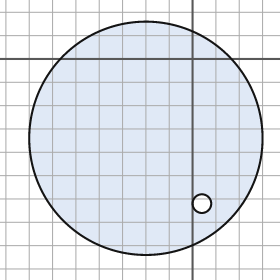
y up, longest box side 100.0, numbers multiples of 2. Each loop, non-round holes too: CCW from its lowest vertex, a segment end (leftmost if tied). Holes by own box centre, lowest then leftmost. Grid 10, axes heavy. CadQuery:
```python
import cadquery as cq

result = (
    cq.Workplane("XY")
    .moveTo(-20.0, -34.0)
    .circle(50.0)
    .moveTo(4.0, -62.0)
    .circle(4.0)
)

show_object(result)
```